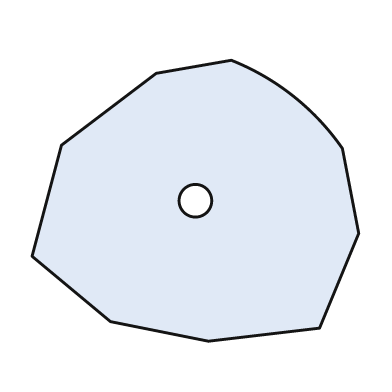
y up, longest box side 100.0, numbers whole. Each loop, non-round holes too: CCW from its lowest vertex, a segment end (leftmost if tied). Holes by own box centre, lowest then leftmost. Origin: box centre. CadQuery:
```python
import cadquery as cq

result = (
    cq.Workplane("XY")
    .moveTo(4.0, -43.0)
    .lineTo(38.0, -39.0)
    .lineTo(50.0, -10.0)
    .lineTo(45.0, 16.0)
    .threePointArc((30.0, 32.0), (11.0, 43.0))
    .lineTo(-12.0, 39.0)
    .lineTo(-41.0, 17.0)
    .lineTo(-50.0, -17.0)
    .lineTo(-26.0, -37.0)
    .close()
    .moveTo(0.0, 0.0)
    .circle(5.0)
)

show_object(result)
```